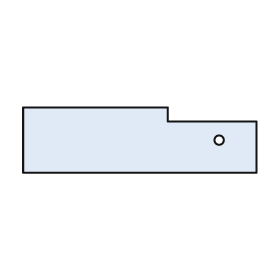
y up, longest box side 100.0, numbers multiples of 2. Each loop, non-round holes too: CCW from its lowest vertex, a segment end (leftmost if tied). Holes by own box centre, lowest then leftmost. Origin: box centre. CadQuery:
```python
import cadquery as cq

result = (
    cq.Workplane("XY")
    .moveTo(-50.0, -14.0)
    .lineTo(50.0, -14.0)
    .lineTo(50.0, 8.0)
    .lineTo(12.0, 8.0)
    .lineTo(12.0, 14.0)
    .lineTo(-50.0, 14.0)
    .close()
    .moveTo(34.0, 0.0)
    .circle(2.0)
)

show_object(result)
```